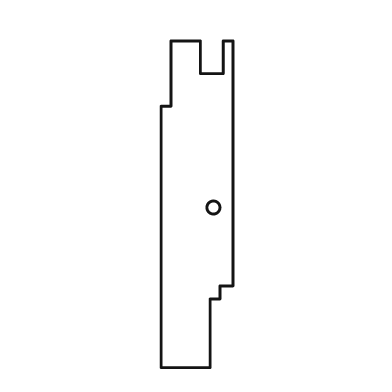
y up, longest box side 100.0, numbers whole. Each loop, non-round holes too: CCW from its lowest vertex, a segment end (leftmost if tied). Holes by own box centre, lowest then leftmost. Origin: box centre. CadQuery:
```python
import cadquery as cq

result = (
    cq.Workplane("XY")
    .moveTo(-11.0, -50.0)
    .lineTo(4.0, -50.0)
    .lineTo(4.0, -29.0)
    .lineTo(7.0, -29.0)
    .lineTo(7.0, -25.0)
    .lineTo(11.0, -25.0)
    .lineTo(11.0, 50.0)
    .lineTo(8.0, 50.0)
    .lineTo(8.0, 40.0)
    .lineTo(1.0, 40.0)
    .lineTo(1.0, 50.0)
    .lineTo(-8.0, 50.0)
    .lineTo(-8.0, 30.0)
    .lineTo(-11.0, 30.0)
    .close()
    .moveTo(5.0, -1.0)
    .circle(2.0)
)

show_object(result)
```